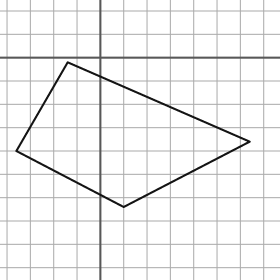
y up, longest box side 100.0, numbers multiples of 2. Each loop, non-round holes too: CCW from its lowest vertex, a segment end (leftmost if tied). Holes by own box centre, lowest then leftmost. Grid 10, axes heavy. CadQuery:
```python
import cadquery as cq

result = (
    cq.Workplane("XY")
    .moveTo(10.0, -64.0)
    .lineTo(64.0, -36.0)
    .lineTo(-14.0, -2.0)
    .lineTo(-36.0, -40.0)
    .close()
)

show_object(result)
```